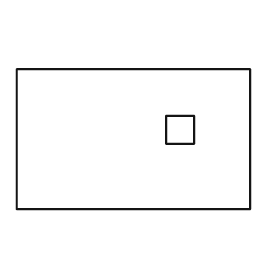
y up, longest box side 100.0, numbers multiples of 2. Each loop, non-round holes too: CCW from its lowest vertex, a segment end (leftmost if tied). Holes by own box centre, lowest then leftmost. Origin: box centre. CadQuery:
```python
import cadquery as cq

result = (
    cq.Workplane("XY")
    .moveTo(-50.0, -30.0)
    .lineTo(50.0, -30.0)
    .lineTo(50.0, 30.0)
    .lineTo(-50.0, 30.0)
    .close()
    .moveTo(14.0, -2.0)
    .lineTo(26.0, -2.0)
    .lineTo(26.0, 10.0)
    .lineTo(14.0, 10.0)
    .close()
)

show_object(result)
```